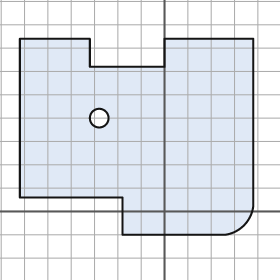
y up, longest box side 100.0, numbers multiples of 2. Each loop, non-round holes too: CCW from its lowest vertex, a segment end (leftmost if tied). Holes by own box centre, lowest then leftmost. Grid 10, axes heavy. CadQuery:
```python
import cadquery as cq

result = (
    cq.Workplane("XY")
    .moveTo(-18.0, -10.0)
    .lineTo(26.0, -10.0)
    .threePointArc((34.0, -6.0), (38.0, 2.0))
    .lineTo(38.0, 74.0)
    .lineTo(0.0, 74.0)
    .lineTo(0.0, 62.0)
    .lineTo(-32.0, 62.0)
    .lineTo(-32.0, 74.0)
    .lineTo(-62.0, 74.0)
    .lineTo(-62.0, 6.0)
    .lineTo(-18.0, 6.0)
    .close()
    .moveTo(-28.0, 40.0)
    .circle(4.0)
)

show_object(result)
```